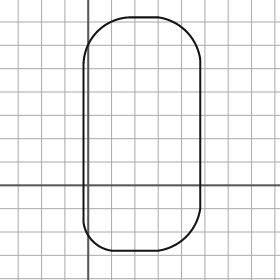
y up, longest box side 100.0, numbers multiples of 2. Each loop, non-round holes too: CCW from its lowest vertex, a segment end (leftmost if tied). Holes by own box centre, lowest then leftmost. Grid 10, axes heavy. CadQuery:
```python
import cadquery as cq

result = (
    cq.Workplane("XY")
    .moveTo(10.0, -28.0)
    .lineTo(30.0, -28.0)
    .threePointArc((42.0, -22.0), (48.0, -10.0))
    .lineTo(48.0, 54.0)
    .threePointArc((42.0, 66.0), (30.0, 72.0))
    .lineTo(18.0, 72.0)
    .threePointArc((4.0, 66.0), (-2.0, 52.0))
    .lineTo(-2.0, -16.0)
    .threePointArc((2.0, -24.0), (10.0, -28.0))
    .close()
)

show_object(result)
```